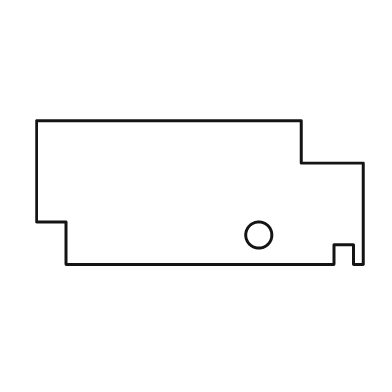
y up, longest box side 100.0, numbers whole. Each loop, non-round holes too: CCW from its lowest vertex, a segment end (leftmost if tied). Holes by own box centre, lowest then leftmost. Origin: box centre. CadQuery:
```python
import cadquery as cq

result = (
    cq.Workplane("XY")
    .moveTo(-41.0, -22.0)
    .lineTo(41.0, -22.0)
    .lineTo(41.0, -16.0)
    .lineTo(47.0, -16.0)
    .lineTo(47.0, -22.0)
    .lineTo(50.0, -22.0)
    .lineTo(50.0, 9.0)
    .lineTo(31.0, 9.0)
    .lineTo(31.0, 22.0)
    .lineTo(-50.0, 22.0)
    .lineTo(-50.0, -9.0)
    .lineTo(-41.0, -9.0)
    .close()
    .moveTo(18.0, -13.0)
    .circle(4.0)
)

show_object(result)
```